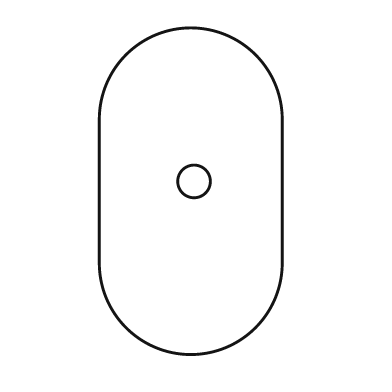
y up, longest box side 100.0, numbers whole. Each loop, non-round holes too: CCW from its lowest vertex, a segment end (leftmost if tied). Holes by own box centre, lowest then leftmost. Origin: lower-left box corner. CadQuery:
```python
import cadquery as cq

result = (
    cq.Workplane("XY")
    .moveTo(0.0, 28.0)
    .threePointArc((28.0, 0.0), (56.0, 28.0))
    .lineTo(56.0, 72.0)
    .threePointArc((28.0, 100.0), (0.0, 72.0))
    .close()
    .moveTo(29.0, 53.0)
    .circle(5.0)
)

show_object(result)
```